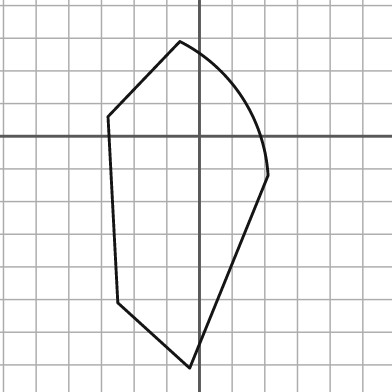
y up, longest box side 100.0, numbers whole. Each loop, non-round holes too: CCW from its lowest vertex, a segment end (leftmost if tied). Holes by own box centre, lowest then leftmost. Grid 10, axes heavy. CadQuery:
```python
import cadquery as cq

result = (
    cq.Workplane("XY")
    .moveTo(-3.0, -71.0)
    .lineTo(21.0, -12.0)
    .threePointArc((13.0, 12.0), (-6.0, 29.0))
    .lineTo(-28.0, 6.0)
    .lineTo(-25.0, -51.0)
    .close()
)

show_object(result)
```